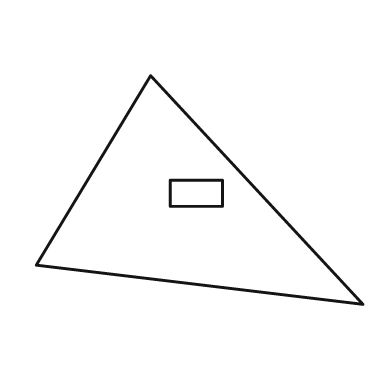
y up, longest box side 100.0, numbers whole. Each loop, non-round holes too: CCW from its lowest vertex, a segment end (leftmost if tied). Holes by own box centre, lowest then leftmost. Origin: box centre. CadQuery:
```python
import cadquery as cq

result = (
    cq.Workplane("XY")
    .moveTo(50.0, -35.0)
    .lineTo(-15.0, 35.0)
    .lineTo(-50.0, -23.0)
    .close()
    .moveTo(-9.0, -5.0)
    .lineTo(7.0, -5.0)
    .lineTo(7.0, 3.0)
    .lineTo(-9.0, 3.0)
    .close()
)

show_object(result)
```